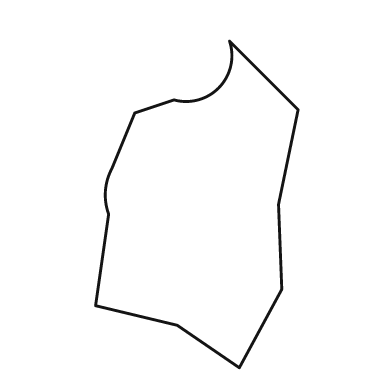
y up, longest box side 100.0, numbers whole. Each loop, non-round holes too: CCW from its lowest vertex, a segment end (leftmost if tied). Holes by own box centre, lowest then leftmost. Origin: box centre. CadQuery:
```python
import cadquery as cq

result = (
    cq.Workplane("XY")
    .moveTo(13.0, -50.0)
    .lineTo(26.0, -26.0)
    .lineTo(25.0, 0.0)
    .lineTo(31.0, 29.0)
    .lineTo(10.0, 50.0)
    .threePointArc((7.0, 36.0), (-7.0, 32.0))
    .lineTo(-19.0, 28.0)
    .lineTo(-26.0, 11.0)
    .threePointArc((-28.0, 4.0), (-27.0, -3.0))
    .lineTo(-31.0, -31.0)
    .lineTo(-6.0, -37.0)
    .close()
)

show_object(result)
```